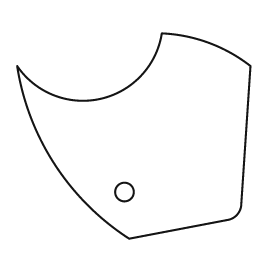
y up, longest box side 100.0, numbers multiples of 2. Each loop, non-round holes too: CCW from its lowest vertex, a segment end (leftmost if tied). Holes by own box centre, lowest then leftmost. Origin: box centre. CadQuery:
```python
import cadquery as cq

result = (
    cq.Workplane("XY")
    .moveTo(-2.0, -44.0)
    .lineTo(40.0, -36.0)
    .threePointArc((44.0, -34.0), (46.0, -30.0))
    .lineTo(50.0, 30.0)
    .threePointArc((32.0, 40.0), (12.0, 44.0))
    .threePointArc((-14.0, 16.0), (-50.0, 30.0))
    .threePointArc((-34.0, -12.0), (-2.0, -44.0))
    .close()
    .moveTo(-4.0, -24.0)
    .circle(4.0)
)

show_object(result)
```